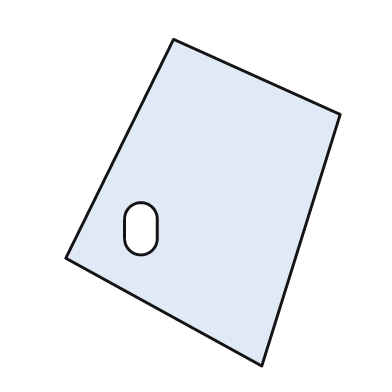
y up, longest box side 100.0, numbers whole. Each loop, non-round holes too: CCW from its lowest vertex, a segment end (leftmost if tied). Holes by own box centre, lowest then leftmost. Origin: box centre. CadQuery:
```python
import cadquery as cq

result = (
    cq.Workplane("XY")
    .moveTo(18.0, -50.0)
    .lineTo(42.0, 27.0)
    .lineTo(-9.0, 50.0)
    .lineTo(-42.0, -17.0)
    .close()
    .moveTo(-24.0, -11.0)
    .threePointArc((-19.0, -16.0), (-14.0, -11.0))
    .lineTo(-14.0, -5.0)
    .threePointArc((-19.0, 0.0), (-24.0, -5.0))
    .close()
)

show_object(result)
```